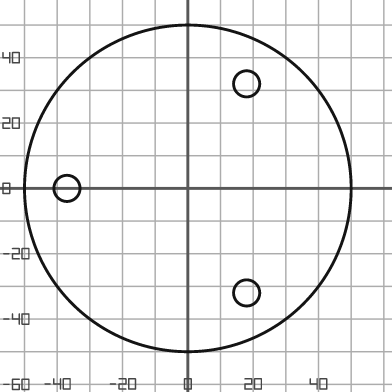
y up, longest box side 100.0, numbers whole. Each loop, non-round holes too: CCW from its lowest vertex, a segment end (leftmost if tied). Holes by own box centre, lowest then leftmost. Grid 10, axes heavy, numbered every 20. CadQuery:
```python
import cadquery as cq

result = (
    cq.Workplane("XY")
    .moveTo(0.0, 0.0)
    .circle(50.0)
    .moveTo(18.0, -32.0)
    .circle(4.0)
    .moveTo(-37.0, 0.0)
    .circle(4.0)
    .moveTo(18.0, 32.0)
    .circle(4.0)
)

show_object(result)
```